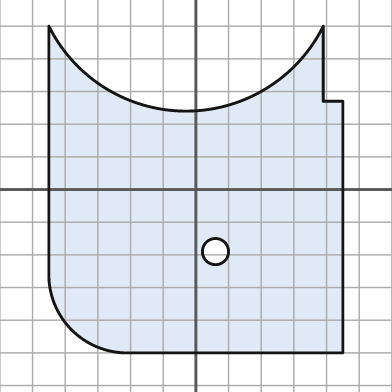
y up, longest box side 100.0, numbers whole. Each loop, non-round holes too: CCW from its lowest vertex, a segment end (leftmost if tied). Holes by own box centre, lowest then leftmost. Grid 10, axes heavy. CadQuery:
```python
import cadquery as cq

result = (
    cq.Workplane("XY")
    .moveTo(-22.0, -50.0)
    .lineTo(45.0, -50.0)
    .lineTo(45.0, 27.0)
    .lineTo(39.0, 27.0)
    .lineTo(39.0, 50.0)
    .threePointArc((-3.0, 24.0), (-45.0, 50.0))
    .lineTo(-45.0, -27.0)
    .threePointArc((-38.0, -43.0), (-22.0, -50.0))
    .close()
    .moveTo(6.0, -19.0)
    .circle(4.0)
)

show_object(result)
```